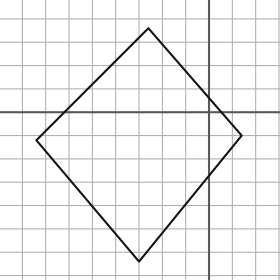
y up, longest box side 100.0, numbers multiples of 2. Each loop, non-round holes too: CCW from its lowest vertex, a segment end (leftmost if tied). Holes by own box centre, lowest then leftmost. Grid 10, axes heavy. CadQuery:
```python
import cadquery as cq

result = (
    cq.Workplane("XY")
    .moveTo(-30.0, -64.0)
    .lineTo(14.0, -10.0)
    .lineTo(-26.0, 36.0)
    .lineTo(-74.0, -12.0)
    .close()
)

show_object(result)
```